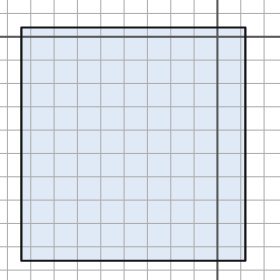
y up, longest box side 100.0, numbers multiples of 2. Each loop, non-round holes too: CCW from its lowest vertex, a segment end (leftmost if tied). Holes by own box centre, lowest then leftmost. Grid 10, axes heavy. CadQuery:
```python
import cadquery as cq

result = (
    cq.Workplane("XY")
    .moveTo(-84.0, -96.0)
    .lineTo(12.0, -96.0)
    .lineTo(12.0, 4.0)
    .lineTo(-84.0, 4.0)
    .close()
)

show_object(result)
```